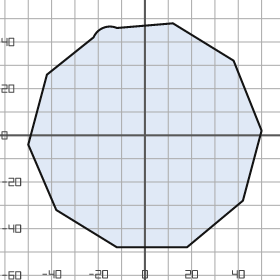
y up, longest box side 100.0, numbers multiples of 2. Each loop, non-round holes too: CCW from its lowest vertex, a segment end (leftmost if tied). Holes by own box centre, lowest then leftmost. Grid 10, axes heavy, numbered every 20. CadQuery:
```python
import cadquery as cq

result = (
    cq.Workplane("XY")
    .moveTo(-12.0, -48.0)
    .lineTo(18.0, -48.0)
    .lineTo(42.0, -28.0)
    .lineTo(50.0, 2.0)
    .lineTo(38.0, 32.0)
    .lineTo(12.0, 48.0)
    .lineTo(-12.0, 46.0)
    .threePointArc((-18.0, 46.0), (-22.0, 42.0))
    .lineTo(-42.0, 26.0)
    .lineTo(-50.0, -4.0)
    .lineTo(-38.0, -32.0)
    .close()
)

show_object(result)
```